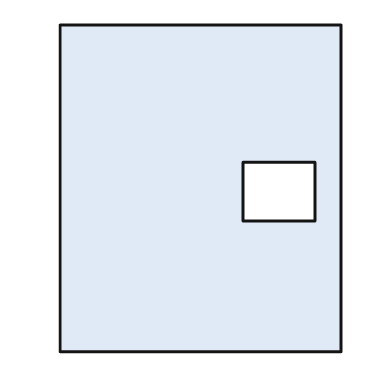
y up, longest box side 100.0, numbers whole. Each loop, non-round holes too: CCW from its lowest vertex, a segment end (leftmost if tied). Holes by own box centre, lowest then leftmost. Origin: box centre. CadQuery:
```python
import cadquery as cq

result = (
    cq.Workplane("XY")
    .moveTo(-43.0, -50.0)
    .lineTo(43.0, -50.0)
    .lineTo(43.0, 50.0)
    .lineTo(-43.0, 50.0)
    .close()
    .moveTo(13.0, -10.0)
    .lineTo(35.0, -10.0)
    .lineTo(35.0, 8.0)
    .lineTo(13.0, 8.0)
    .close()
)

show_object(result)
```